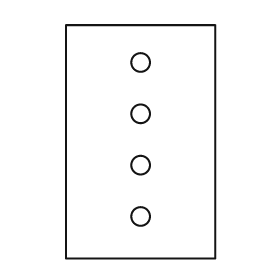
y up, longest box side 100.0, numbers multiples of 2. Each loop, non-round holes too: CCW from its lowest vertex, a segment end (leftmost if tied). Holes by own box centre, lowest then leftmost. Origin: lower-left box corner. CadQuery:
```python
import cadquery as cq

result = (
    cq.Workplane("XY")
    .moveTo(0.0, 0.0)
    .lineTo(64.0, 0.0)
    .lineTo(64.0, 100.0)
    .lineTo(0.0, 100.0)
    .close()
    .moveTo(32.0, 18.0)
    .circle(4.0)
    .moveTo(32.0, 40.0)
    .circle(4.0)
    .moveTo(32.0, 62.0)
    .circle(4.0)
    .moveTo(32.0, 84.0)
    .circle(4.0)
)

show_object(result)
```